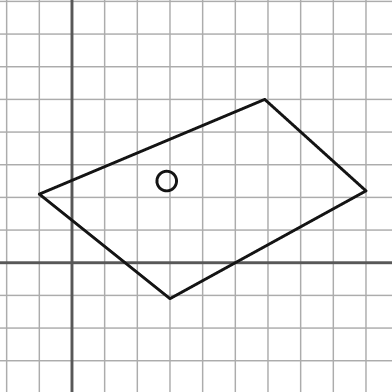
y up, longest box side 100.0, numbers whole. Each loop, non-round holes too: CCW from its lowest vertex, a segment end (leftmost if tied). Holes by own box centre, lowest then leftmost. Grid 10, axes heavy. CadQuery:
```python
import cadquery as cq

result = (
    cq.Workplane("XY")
    .moveTo(30.0, -11.0)
    .lineTo(90.0, 22.0)
    .lineTo(59.0, 50.0)
    .lineTo(-10.0, 21.0)
    .close()
    .moveTo(29.0, 25.0)
    .circle(3.0)
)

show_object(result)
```